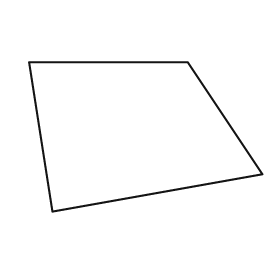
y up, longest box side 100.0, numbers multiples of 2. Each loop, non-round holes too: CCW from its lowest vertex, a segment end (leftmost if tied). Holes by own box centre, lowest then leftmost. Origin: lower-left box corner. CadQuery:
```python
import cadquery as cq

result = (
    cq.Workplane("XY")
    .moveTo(10.0, 0.0)
    .lineTo(100.0, 16.0)
    .lineTo(68.0, 64.0)
    .lineTo(0.0, 64.0)
    .close()
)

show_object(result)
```